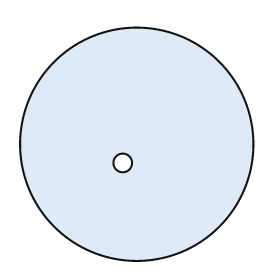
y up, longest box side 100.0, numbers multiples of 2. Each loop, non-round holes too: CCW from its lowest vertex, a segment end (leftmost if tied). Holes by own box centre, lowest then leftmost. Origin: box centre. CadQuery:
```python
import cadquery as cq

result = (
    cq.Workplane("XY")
    .moveTo(0.0, 0.0)
    .circle(50.0)
    .moveTo(-6.0, -8.0)
    .circle(4.0)
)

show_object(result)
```